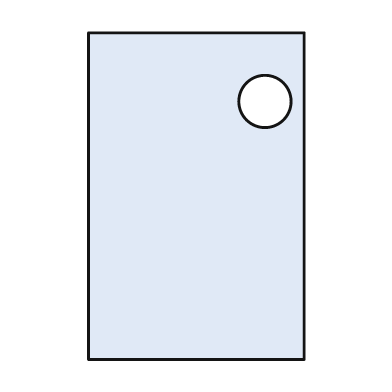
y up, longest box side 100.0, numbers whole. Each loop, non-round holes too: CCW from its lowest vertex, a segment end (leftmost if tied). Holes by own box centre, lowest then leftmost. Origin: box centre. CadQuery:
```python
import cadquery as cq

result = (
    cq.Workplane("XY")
    .moveTo(-33.0, -50.0)
    .lineTo(33.0, -50.0)
    .lineTo(33.0, 50.0)
    .lineTo(-33.0, 50.0)
    .close()
    .moveTo(21.0, 29.0)
    .circle(8.0)
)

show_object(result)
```